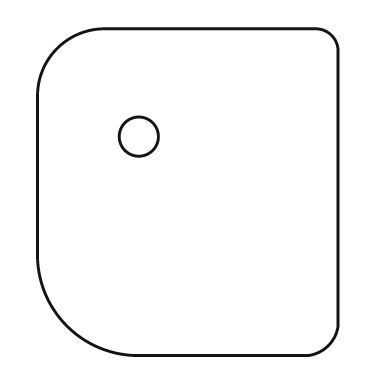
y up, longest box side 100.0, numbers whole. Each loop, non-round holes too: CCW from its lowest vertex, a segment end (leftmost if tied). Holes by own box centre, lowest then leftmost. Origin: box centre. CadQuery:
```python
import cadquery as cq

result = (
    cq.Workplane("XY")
    .moveTo(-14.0, -50.0)
    .lineTo(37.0, -50.0)
    .threePointArc((43.0, -47.0), (46.0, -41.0))
    .lineTo(46.0, 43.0)
    .threePointArc((44.0, 48.0), (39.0, 50.0))
    .lineTo(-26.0, 50.0)
    .threePointArc((-40.0, 44.0), (-46.0, 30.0))
    .lineTo(-46.0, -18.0)
    .threePointArc((-37.0, -41.0), (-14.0, -50.0))
    .close()
    .moveTo(-15.0, 17.0)
    .circle(6.0)
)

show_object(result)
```